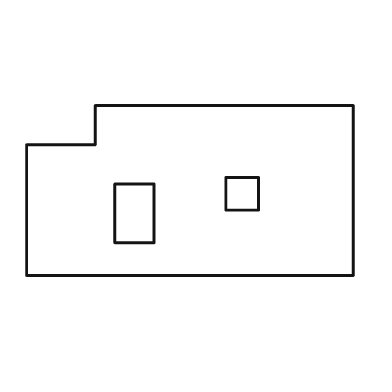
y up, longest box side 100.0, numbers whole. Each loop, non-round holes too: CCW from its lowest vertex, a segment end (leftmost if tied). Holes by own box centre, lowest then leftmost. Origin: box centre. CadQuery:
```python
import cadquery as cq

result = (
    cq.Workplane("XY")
    .moveTo(-50.0, -26.0)
    .lineTo(50.0, -26.0)
    .lineTo(50.0, 26.0)
    .lineTo(-29.0, 26.0)
    .lineTo(-29.0, 14.0)
    .lineTo(-50.0, 14.0)
    .close()
    .moveTo(-23.0, -16.0)
    .lineTo(-11.0, -16.0)
    .lineTo(-11.0, 2.0)
    .lineTo(-23.0, 2.0)
    .close()
    .moveTo(11.0, -6.0)
    .lineTo(21.0, -6.0)
    .lineTo(21.0, 4.0)
    .lineTo(11.0, 4.0)
    .close()
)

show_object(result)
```